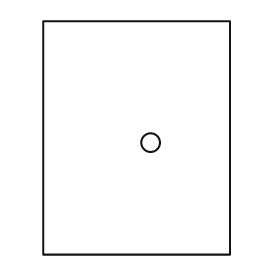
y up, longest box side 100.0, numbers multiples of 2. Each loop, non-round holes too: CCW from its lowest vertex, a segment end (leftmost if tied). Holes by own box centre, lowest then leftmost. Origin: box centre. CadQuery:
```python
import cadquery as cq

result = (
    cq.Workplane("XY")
    .moveTo(-40.0, -50.0)
    .lineTo(40.0, -50.0)
    .lineTo(40.0, 50.0)
    .lineTo(-40.0, 50.0)
    .close()
    .moveTo(6.0, -2.0)
    .circle(4.0)
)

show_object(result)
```